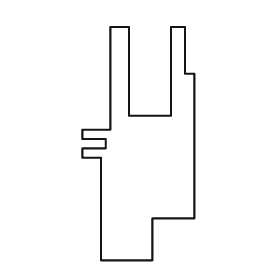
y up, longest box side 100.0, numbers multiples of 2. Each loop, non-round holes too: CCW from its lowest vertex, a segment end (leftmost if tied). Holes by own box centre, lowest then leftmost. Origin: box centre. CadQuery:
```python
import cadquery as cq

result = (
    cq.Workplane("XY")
    .moveTo(-16.0, -50.0)
    .lineTo(6.0, -50.0)
    .lineTo(6.0, -32.0)
    .lineTo(24.0, -32.0)
    .lineTo(24.0, 30.0)
    .lineTo(20.0, 30.0)
    .lineTo(20.0, 50.0)
    .lineTo(14.0, 50.0)
    .lineTo(14.0, 12.0)
    .lineTo(-4.0, 12.0)
    .lineTo(-4.0, 50.0)
    .lineTo(-12.0, 50.0)
    .lineTo(-12.0, 6.0)
    .lineTo(-24.0, 6.0)
    .lineTo(-24.0, 2.0)
    .lineTo(-14.0, 2.0)
    .lineTo(-14.0, -2.0)
    .lineTo(-24.0, -2.0)
    .lineTo(-24.0, -6.0)
    .lineTo(-16.0, -6.0)
    .close()
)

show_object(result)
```